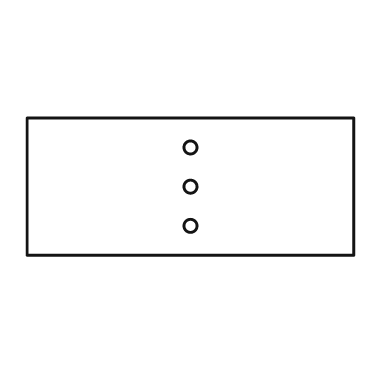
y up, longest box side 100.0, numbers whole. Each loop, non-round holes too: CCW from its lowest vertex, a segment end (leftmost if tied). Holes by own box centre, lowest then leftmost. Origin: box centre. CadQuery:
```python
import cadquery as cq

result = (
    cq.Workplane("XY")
    .moveTo(-50.0, -21.0)
    .lineTo(50.0, -21.0)
    .lineTo(50.0, 21.0)
    .lineTo(-50.0, 21.0)
    .close()
    .moveTo(0.0, -12.0)
    .circle(2.0)
    .moveTo(0.0, 0.0)
    .circle(2.0)
    .moveTo(0.0, 12.0)
    .circle(2.0)
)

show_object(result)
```